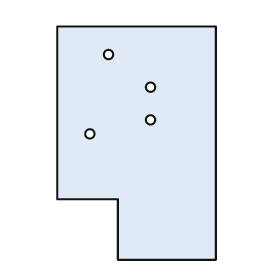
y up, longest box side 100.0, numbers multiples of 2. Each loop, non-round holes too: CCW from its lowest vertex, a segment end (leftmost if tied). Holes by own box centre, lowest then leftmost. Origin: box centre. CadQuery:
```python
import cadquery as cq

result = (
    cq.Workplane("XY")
    .moveTo(-8.0, -50.0)
    .lineTo(34.0, -50.0)
    .lineTo(34.0, 50.0)
    .lineTo(-34.0, 50.0)
    .lineTo(-34.0, -24.0)
    .lineTo(-8.0, -24.0)
    .close()
    .moveTo(-20.0, 4.0)
    .circle(2.0)
    .moveTo(6.0, 10.0)
    .circle(2.0)
    .moveTo(6.0, 24.0)
    .circle(2.0)
    .moveTo(-12.0, 38.0)
    .circle(2.0)
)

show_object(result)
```